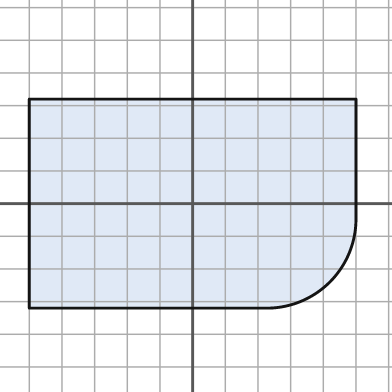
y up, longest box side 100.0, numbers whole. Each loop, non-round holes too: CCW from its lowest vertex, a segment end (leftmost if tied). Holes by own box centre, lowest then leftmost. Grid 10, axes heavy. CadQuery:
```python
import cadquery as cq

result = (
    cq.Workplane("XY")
    .moveTo(-50.0, -32.0)
    .lineTo(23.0, -32.0)
    .threePointArc((42.0, -24.0), (50.0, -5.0))
    .lineTo(50.0, 32.0)
    .lineTo(-50.0, 32.0)
    .close()
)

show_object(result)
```